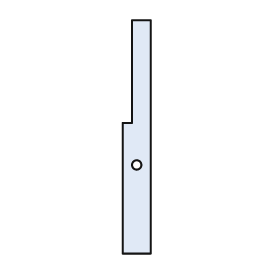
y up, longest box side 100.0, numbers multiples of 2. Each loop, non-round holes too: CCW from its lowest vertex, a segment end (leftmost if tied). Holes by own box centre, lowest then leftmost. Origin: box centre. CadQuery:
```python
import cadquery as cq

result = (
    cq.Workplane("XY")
    .moveTo(-6.0, -50.0)
    .lineTo(6.0, -50.0)
    .lineTo(6.0, 50.0)
    .lineTo(-2.0, 50.0)
    .lineTo(-2.0, 6.0)
    .lineTo(-6.0, 6.0)
    .close()
    .moveTo(0.0, -12.0)
    .circle(2.0)
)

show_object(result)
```